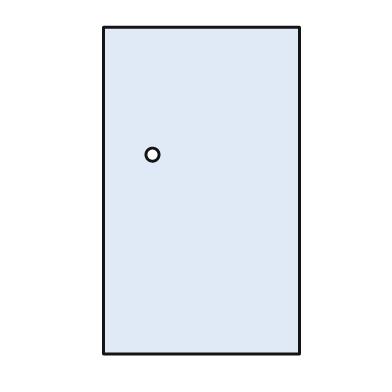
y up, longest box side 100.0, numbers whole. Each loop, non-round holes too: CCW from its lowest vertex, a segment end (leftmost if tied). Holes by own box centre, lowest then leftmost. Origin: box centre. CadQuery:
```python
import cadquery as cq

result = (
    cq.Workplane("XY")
    .moveTo(-30.0, -50.0)
    .lineTo(30.0, -50.0)
    .lineTo(30.0, 50.0)
    .lineTo(-30.0, 50.0)
    .close()
    .moveTo(-15.0, 11.0)
    .circle(2.0)
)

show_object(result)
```